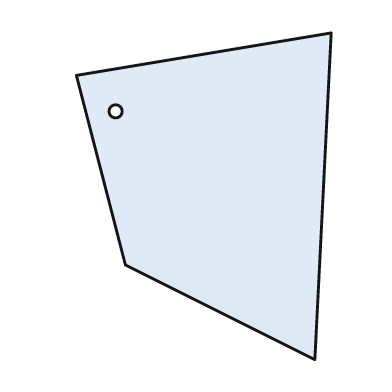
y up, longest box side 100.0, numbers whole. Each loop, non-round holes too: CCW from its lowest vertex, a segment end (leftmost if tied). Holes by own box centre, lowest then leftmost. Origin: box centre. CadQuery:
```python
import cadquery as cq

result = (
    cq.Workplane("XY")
    .moveTo(34.0, -50.0)
    .lineTo(39.0, 50.0)
    .lineTo(-39.0, 37.0)
    .lineTo(-24.0, -21.0)
    .close()
    .moveTo(-27.0, 26.0)
    .circle(2.0)
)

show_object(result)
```